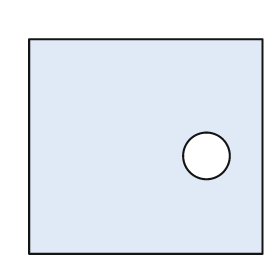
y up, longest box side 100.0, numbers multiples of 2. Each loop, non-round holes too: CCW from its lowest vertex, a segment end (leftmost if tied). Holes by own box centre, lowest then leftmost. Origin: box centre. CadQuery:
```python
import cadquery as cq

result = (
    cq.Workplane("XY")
    .moveTo(-50.0, -46.0)
    .lineTo(50.0, -46.0)
    .lineTo(50.0, 46.0)
    .lineTo(-50.0, 46.0)
    .close()
    .moveTo(26.0, -4.0)
    .circle(10.0)
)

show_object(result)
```